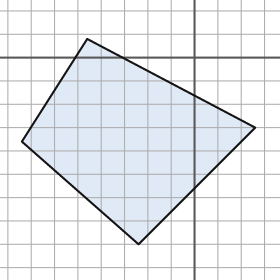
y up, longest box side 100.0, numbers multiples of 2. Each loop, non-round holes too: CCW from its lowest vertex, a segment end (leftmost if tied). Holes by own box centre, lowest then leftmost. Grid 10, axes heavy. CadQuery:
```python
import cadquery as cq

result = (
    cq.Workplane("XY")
    .moveTo(-24.0, -80.0)
    .lineTo(26.0, -30.0)
    .lineTo(-46.0, 8.0)
    .lineTo(-74.0, -36.0)
    .close()
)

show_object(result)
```